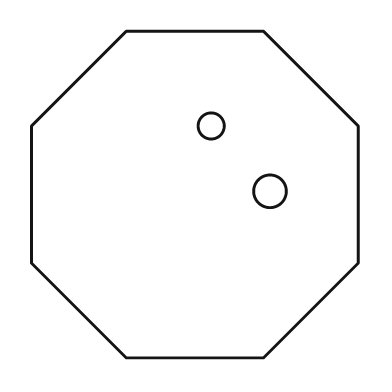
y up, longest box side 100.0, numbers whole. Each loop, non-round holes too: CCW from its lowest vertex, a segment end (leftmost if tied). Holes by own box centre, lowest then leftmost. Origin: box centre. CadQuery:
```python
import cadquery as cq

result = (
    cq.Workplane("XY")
    .moveTo(-21.0, -50.0)
    .lineTo(21.0, -50.0)
    .lineTo(50.0, -21.0)
    .lineTo(50.0, 21.0)
    .lineTo(21.0, 50.0)
    .lineTo(-21.0, 50.0)
    .lineTo(-50.0, 21.0)
    .lineTo(-50.0, -21.0)
    .close()
    .moveTo(23.0, 1.0)
    .circle(5.0)
    .moveTo(5.0, 21.0)
    .circle(4.0)
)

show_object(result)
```